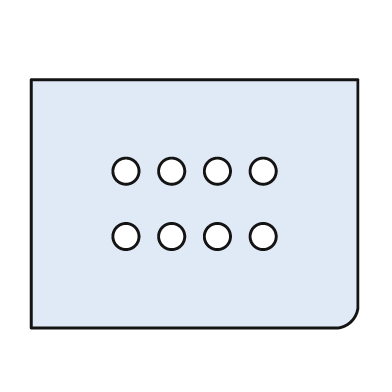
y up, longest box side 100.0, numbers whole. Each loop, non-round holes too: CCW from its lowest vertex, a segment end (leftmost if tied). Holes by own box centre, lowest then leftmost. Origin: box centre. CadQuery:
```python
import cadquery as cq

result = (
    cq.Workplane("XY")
    .moveTo(-50.0, -38.0)
    .lineTo(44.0, -38.0)
    .threePointArc((48.0, -36.0), (50.0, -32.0))
    .lineTo(50.0, 38.0)
    .lineTo(-50.0, 38.0)
    .close()
    .moveTo(-21.0, -10.0)
    .circle(4.0)
    .moveTo(-7.0, -10.0)
    .circle(4.0)
    .moveTo(7.0, -10.0)
    .circle(4.0)
    .moveTo(21.0, -10.0)
    .circle(4.0)
    .moveTo(-21.0, 10.0)
    .circle(4.0)
    .moveTo(-7.0, 10.0)
    .circle(4.0)
    .moveTo(7.0, 10.0)
    .circle(4.0)
    .moveTo(21.0, 10.0)
    .circle(4.0)
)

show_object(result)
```